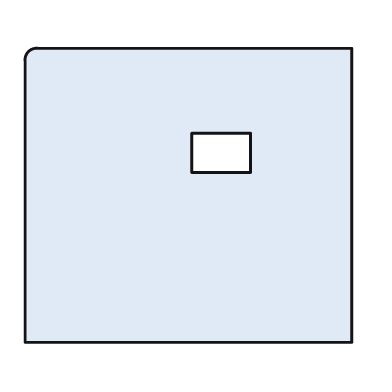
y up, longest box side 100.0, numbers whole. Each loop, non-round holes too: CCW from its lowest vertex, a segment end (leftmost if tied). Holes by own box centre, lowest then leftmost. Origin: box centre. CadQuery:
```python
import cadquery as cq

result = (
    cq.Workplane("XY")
    .moveTo(-50.0, -45.0)
    .lineTo(50.0, -45.0)
    .lineTo(50.0, 45.0)
    .lineTo(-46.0, 45.0)
    .threePointArc((-49.0, 44.0), (-50.0, 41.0))
    .close()
    .moveTo(1.0, 7.0)
    .lineTo(19.0, 7.0)
    .lineTo(19.0, 19.0)
    .lineTo(1.0, 19.0)
    .close()
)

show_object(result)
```